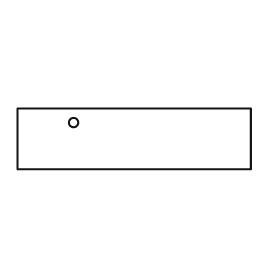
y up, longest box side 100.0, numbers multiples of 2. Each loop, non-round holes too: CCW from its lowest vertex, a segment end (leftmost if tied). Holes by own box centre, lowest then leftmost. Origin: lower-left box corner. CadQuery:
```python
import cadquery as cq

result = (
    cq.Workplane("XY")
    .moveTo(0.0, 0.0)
    .lineTo(100.0, 0.0)
    .lineTo(100.0, 26.0)
    .lineTo(0.0, 26.0)
    .close()
    .moveTo(24.0, 20.0)
    .circle(2.0)
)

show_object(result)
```